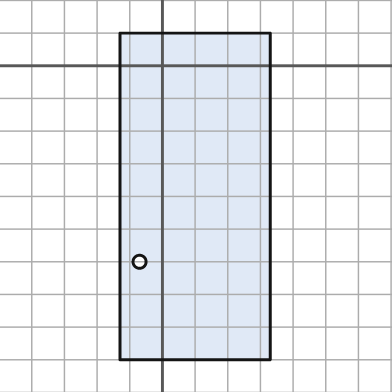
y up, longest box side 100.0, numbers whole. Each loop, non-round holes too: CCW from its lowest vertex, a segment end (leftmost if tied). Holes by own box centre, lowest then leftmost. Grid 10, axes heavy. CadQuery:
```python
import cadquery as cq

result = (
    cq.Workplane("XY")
    .moveTo(-13.0, -90.0)
    .lineTo(33.0, -90.0)
    .lineTo(33.0, 10.0)
    .lineTo(-13.0, 10.0)
    .close()
    .moveTo(-7.0, -60.0)
    .circle(2.0)
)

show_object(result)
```